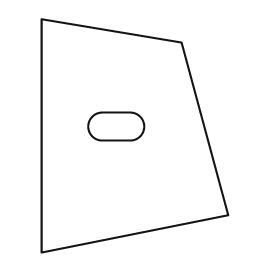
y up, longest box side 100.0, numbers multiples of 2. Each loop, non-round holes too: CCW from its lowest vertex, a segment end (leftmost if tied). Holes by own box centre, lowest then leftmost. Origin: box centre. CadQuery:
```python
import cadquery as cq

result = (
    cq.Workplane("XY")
    .moveTo(-40.0, -50.0)
    .lineTo(40.0, -34.0)
    .lineTo(20.0, 40.0)
    .lineTo(-40.0, 50.0)
    .close()
    .moveTo(-14.0, -2.0)
    .lineTo(-2.0, -2.0)
    .threePointArc((4.0, 4.0), (-2.0, 10.0))
    .lineTo(-14.0, 10.0)
    .threePointArc((-20.0, 4.0), (-14.0, -2.0))
    .close()
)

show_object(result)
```